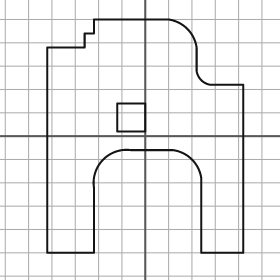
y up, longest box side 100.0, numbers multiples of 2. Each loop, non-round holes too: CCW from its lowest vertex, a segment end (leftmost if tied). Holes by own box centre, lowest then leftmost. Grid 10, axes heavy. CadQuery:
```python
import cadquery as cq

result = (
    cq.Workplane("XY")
    .moveTo(-42.0, -50.0)
    .lineTo(-22.0, -50.0)
    .lineTo(-22.0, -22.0)
    .threePointArc((-18.0, -10.0), (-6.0, -6.0))
    .lineTo(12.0, -6.0)
    .threePointArc((20.0, -10.0), (24.0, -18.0))
    .lineTo(24.0, -50.0)
    .lineTo(42.0, -50.0)
    .lineTo(42.0, 22.0)
    .lineTo(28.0, 22.0)
    .threePointArc((24.0, 24.0), (22.0, 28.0))
    .lineTo(22.0, 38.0)
    .threePointArc((18.0, 46.0), (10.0, 50.0))
    .lineTo(-22.0, 50.0)
    .lineTo(-22.0, 44.0)
    .lineTo(-26.0, 44.0)
    .lineTo(-26.0, 38.0)
    .lineTo(-42.0, 38.0)
    .close()
    .moveTo(-12.0, 2.0)
    .lineTo(0.0, 2.0)
    .lineTo(0.0, 14.0)
    .lineTo(-12.0, 14.0)
    .close()
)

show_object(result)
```